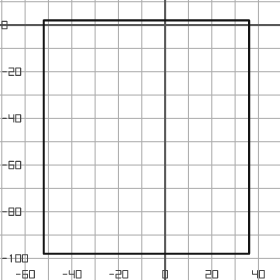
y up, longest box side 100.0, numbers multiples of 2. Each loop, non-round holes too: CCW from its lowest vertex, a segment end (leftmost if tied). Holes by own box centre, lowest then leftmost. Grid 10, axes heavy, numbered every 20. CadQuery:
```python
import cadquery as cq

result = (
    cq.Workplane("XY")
    .moveTo(-52.0, -98.0)
    .lineTo(36.0, -98.0)
    .lineTo(36.0, 2.0)
    .lineTo(-52.0, 2.0)
    .close()
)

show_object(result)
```